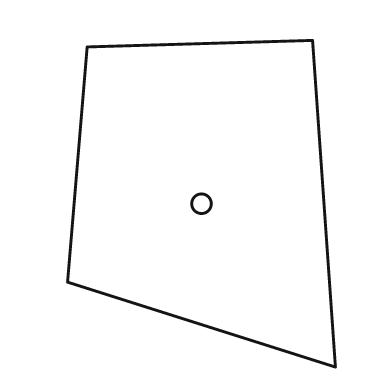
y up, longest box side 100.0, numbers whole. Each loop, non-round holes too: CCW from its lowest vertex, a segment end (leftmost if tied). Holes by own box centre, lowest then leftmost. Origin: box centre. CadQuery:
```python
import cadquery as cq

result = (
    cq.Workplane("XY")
    .moveTo(41.0, -50.0)
    .lineTo(34.0, 50.0)
    .lineTo(-35.0, 48.0)
    .lineTo(-41.0, -24.0)
    .close()
    .moveTo(0.0, 0.0)
    .circle(3.0)
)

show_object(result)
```